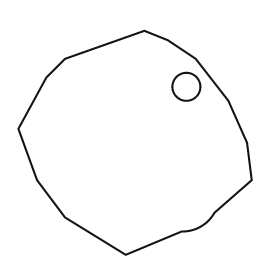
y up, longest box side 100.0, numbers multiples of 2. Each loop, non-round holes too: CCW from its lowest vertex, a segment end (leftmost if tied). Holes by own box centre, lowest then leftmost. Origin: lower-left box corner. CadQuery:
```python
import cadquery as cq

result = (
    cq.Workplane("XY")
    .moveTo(46.0, 0.0)
    .lineTo(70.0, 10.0)
    .threePointArc((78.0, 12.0), (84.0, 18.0))
    .lineTo(100.0, 32.0)
    .lineTo(98.0, 48.0)
    .lineTo(90.0, 66.0)
    .lineTo(76.0, 84.0)
    .lineTo(64.0, 92.0)
    .lineTo(54.0, 96.0)
    .lineTo(20.0, 84.0)
    .lineTo(12.0, 76.0)
    .lineTo(0.0, 54.0)
    .lineTo(8.0, 32.0)
    .lineTo(20.0, 16.0)
    .close()
    .moveTo(72.0, 72.0)
    .circle(6.0)
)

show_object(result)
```